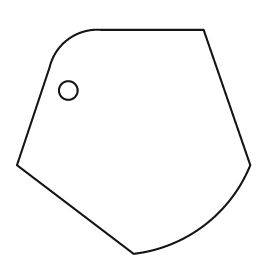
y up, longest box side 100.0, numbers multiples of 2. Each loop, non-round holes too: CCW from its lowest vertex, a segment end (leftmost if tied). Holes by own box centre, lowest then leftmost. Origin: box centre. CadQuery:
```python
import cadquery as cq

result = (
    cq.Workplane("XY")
    .moveTo(0.0, -48.0)
    .threePointArc((30.0, -36.0), (50.0, -10.0))
    .lineTo(30.0, 48.0)
    .lineTo(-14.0, 48.0)
    .threePointArc((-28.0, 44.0), (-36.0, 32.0))
    .lineTo(-50.0, -10.0)
    .close()
    .moveTo(-28.0, 22.0)
    .circle(4.0)
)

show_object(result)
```